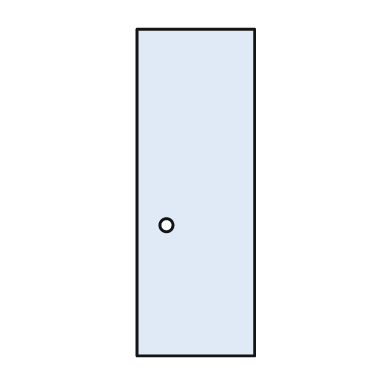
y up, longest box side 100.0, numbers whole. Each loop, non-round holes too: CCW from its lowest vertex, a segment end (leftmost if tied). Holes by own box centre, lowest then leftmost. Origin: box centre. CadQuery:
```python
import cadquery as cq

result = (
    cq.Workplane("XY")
    .moveTo(-18.0, -50.0)
    .lineTo(18.0, -50.0)
    .lineTo(18.0, 50.0)
    .lineTo(-18.0, 50.0)
    .close()
    .moveTo(-9.0, -10.0)
    .circle(2.0)
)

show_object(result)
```